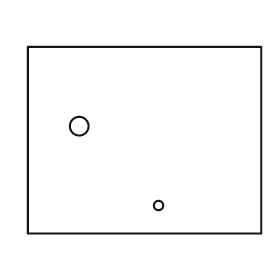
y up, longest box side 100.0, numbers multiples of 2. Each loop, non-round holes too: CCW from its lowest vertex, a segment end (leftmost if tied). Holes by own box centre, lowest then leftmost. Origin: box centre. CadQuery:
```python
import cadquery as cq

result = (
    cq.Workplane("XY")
    .moveTo(-50.0, -40.0)
    .lineTo(50.0, -40.0)
    .lineTo(50.0, 40.0)
    .lineTo(-50.0, 40.0)
    .close()
    .moveTo(6.0, -28.0)
    .circle(2.0)
    .moveTo(-28.0, 6.0)
    .circle(4.0)
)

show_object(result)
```